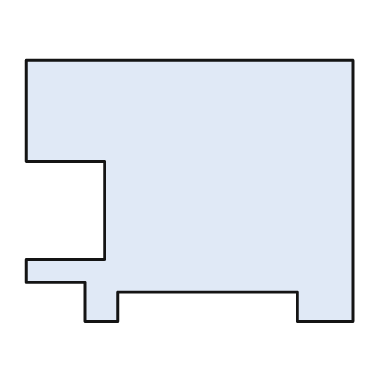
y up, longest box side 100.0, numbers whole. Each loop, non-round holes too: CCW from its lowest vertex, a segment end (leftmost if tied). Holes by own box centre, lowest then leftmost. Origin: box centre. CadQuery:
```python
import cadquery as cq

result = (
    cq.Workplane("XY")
    .moveTo(-32.0, -40.0)
    .lineTo(-22.0, -40.0)
    .lineTo(-22.0, -31.0)
    .lineTo(33.0, -31.0)
    .lineTo(33.0, -40.0)
    .lineTo(50.0, -40.0)
    .lineTo(50.0, 40.0)
    .lineTo(-50.0, 40.0)
    .lineTo(-50.0, 9.0)
    .lineTo(-26.0, 9.0)
    .lineTo(-26.0, -21.0)
    .lineTo(-50.0, -21.0)
    .lineTo(-50.0, -28.0)
    .lineTo(-32.0, -28.0)
    .close()
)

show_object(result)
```